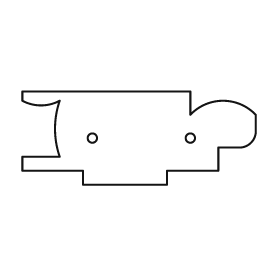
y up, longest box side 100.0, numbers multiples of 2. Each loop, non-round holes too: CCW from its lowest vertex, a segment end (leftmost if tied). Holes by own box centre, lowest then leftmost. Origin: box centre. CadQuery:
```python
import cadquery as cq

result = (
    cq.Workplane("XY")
    .moveTo(-24.0, -20.0)
    .lineTo(12.0, -20.0)
    .lineTo(12.0, -14.0)
    .lineTo(34.0, -14.0)
    .lineTo(34.0, -4.0)
    .lineTo(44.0, -4.0)
    .threePointArc((48.0, -2.0), (50.0, 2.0))
    .lineTo(50.0, 10.0)
    .threePointArc((36.0, 16.0), (22.0, 10.0))
    .lineTo(22.0, 20.0)
    .lineTo(-50.0, 20.0)
    .lineTo(-50.0, 16.0)
    .threePointArc((-42.0, 14.0), (-34.0, 16.0))
    .threePointArc((-36.0, 4.0), (-34.0, -8.0))
    .lineTo(-50.0, -8.0)
    .lineTo(-50.0, -14.0)
    .lineTo(-24.0, -14.0)
    .close()
    .moveTo(-20.0, 0.0)
    .circle(2.0)
    .moveTo(22.0, 0.0)
    .circle(2.0)
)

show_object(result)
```